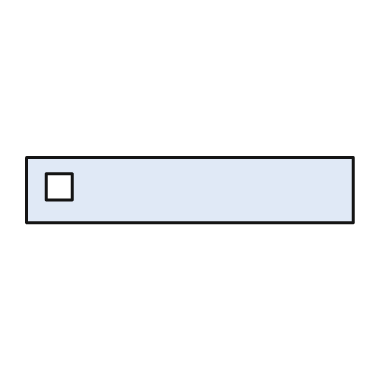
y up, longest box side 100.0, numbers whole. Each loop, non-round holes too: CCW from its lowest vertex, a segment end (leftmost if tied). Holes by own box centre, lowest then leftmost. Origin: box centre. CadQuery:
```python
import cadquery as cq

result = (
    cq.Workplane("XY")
    .moveTo(-50.0, -10.0)
    .lineTo(50.0, -10.0)
    .lineTo(50.0, 10.0)
    .lineTo(-50.0, 10.0)
    .close()
    .moveTo(-44.0, -3.0)
    .lineTo(-36.0, -3.0)
    .lineTo(-36.0, 5.0)
    .lineTo(-44.0, 5.0)
    .close()
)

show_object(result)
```